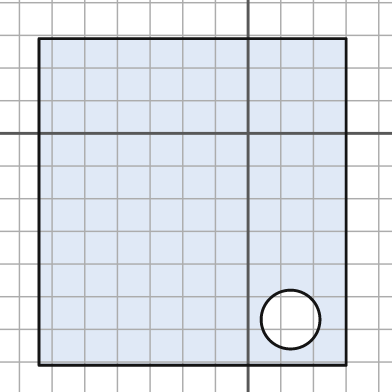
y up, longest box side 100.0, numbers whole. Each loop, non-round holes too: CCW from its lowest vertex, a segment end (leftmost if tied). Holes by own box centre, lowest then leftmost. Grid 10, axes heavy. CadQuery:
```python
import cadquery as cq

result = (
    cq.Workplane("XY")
    .moveTo(-64.0, -71.0)
    .lineTo(30.0, -71.0)
    .lineTo(30.0, 29.0)
    .lineTo(-64.0, 29.0)
    .close()
    .moveTo(13.0, -57.0)
    .circle(9.0)
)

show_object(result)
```